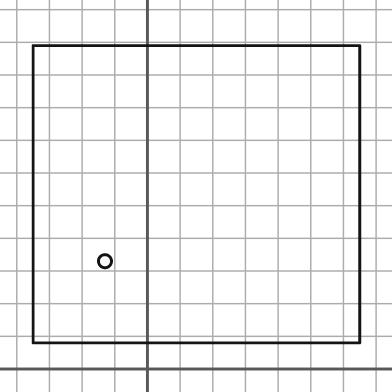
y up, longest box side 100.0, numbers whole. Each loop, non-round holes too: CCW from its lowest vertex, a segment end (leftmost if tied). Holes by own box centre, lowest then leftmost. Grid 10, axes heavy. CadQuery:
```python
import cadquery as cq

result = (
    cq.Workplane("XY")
    .moveTo(-35.0, 8.0)
    .lineTo(65.0, 8.0)
    .lineTo(65.0, 99.0)
    .lineTo(-35.0, 99.0)
    .close()
    .moveTo(-13.0, 33.0)
    .circle(2.0)
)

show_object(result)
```